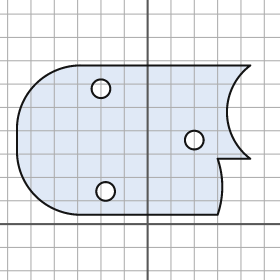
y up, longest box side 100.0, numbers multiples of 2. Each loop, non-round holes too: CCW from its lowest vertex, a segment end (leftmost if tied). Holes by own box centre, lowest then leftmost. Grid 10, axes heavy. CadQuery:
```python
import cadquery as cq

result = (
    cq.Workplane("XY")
    .moveTo(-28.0, 4.0)
    .lineTo(30.0, 4.0)
    .threePointArc((32.0, 16.0), (30.0, 28.0))
    .lineTo(44.0, 28.0)
    .threePointArc((34.0, 48.0), (44.0, 68.0))
    .lineTo(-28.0, 68.0)
    .threePointArc((-48.0, 60.0), (-56.0, 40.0))
    .lineTo(-56.0, 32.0)
    .threePointArc((-48.0, 12.0), (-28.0, 4.0))
    .close()
    .moveTo(-18.0, 14.0)
    .circle(4.0)
    .moveTo(20.0, 36.0)
    .circle(4.0)
    .moveTo(-20.0, 58.0)
    .circle(4.0)
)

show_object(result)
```